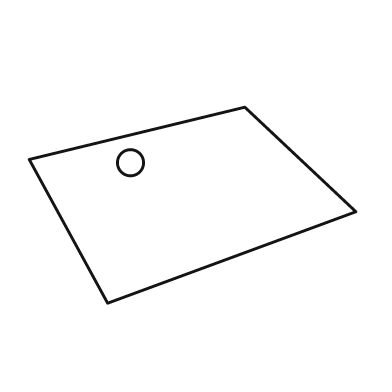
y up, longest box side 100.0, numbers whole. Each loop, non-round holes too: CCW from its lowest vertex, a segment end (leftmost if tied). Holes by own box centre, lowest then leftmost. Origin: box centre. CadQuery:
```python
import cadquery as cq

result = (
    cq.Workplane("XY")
    .moveTo(-26.0, -30.0)
    .lineTo(50.0, -2.0)
    .lineTo(16.0, 30.0)
    .lineTo(-50.0, 14.0)
    .close()
    .moveTo(-19.0, 13.0)
    .circle(4.0)
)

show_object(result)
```